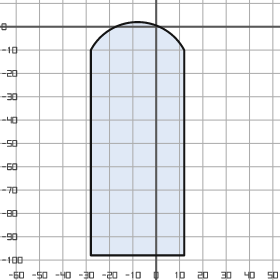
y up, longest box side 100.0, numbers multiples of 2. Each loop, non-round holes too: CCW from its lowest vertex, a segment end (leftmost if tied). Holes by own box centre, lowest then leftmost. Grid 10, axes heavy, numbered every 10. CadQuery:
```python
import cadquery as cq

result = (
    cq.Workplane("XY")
    .moveTo(-28.0, -98.0)
    .lineTo(12.0, -98.0)
    .lineTo(12.0, -10.0)
    .threePointArc((-8.0, 2.0), (-28.0, -10.0))
    .close()
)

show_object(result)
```